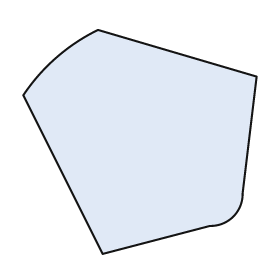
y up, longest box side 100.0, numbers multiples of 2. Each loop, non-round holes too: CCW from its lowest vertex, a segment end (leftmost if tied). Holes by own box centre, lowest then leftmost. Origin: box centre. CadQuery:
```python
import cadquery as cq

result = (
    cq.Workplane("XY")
    .moveTo(-16.0, -48.0)
    .lineTo(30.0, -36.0)
    .threePointArc((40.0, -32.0), (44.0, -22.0))
    .lineTo(50.0, 28.0)
    .lineTo(-18.0, 48.0)
    .threePointArc((-36.0, 36.0), (-50.0, 20.0))
    .close()
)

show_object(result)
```